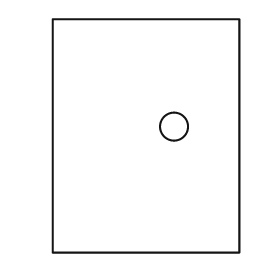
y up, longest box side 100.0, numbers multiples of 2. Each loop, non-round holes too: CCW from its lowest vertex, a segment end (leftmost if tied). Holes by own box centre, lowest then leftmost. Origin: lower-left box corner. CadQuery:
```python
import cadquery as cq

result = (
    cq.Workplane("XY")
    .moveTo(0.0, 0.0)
    .lineTo(80.0, 0.0)
    .lineTo(80.0, 100.0)
    .lineTo(0.0, 100.0)
    .close()
    .moveTo(52.0, 54.0)
    .circle(6.0)
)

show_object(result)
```